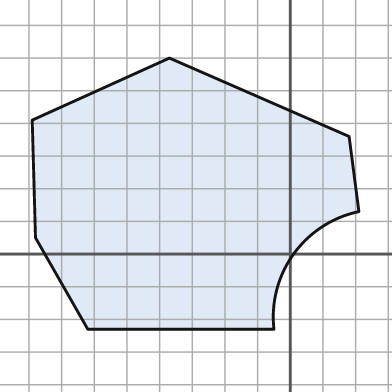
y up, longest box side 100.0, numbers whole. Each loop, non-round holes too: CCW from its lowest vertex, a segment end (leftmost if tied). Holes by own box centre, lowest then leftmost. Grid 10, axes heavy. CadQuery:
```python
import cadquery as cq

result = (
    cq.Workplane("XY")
    .moveTo(-62.0, -23.0)
    .lineTo(-5.0, -23.0)
    .threePointArc((1.0, 0.0), (21.0, 13.0))
    .lineTo(18.0, 36.0)
    .lineTo(-37.0, 60.0)
    .lineTo(-79.0, 41.0)
    .lineTo(-78.0, 5.0)
    .close()
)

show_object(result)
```